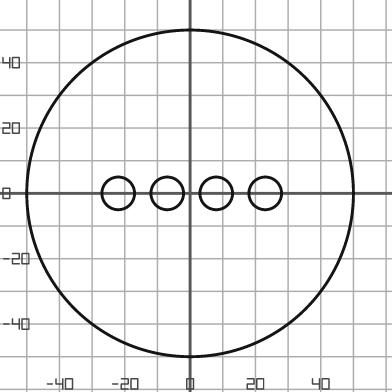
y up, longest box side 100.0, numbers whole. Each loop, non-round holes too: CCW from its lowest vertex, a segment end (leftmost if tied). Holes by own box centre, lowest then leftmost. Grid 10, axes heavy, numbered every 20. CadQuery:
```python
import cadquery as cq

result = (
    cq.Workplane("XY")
    .moveTo(0.0, 0.0)
    .circle(50.0)
    .moveTo(-22.0, 0.0)
    .circle(5.0)
    .moveTo(-7.0, 0.0)
    .circle(5.0)
    .moveTo(8.0, 0.0)
    .circle(5.0)
    .moveTo(23.0, 0.0)
    .circle(5.0)
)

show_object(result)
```